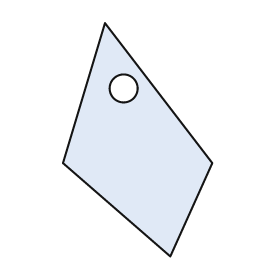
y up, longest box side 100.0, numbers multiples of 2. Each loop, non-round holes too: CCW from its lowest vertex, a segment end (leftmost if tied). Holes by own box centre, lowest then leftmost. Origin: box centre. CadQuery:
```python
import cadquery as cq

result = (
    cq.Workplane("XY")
    .moveTo(14.0, -50.0)
    .lineTo(32.0, -10.0)
    .lineTo(-14.0, 50.0)
    .lineTo(-32.0, -10.0)
    .close()
    .moveTo(-6.0, 22.0)
    .circle(6.0)
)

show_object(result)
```